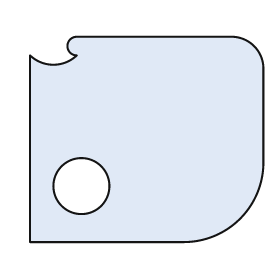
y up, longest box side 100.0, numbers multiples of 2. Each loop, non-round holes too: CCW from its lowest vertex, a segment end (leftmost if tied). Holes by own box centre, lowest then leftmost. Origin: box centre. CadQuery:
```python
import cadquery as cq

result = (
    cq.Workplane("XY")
    .moveTo(-50.0, -44.0)
    .lineTo(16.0, -44.0)
    .threePointArc((40.0, -34.0), (50.0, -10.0))
    .lineTo(50.0, 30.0)
    .threePointArc((46.0, 40.0), (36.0, 44.0))
    .lineTo(-30.0, 44.0)
    .threePointArc((-34.0, 40.0), (-30.0, 36.0))
    .threePointArc((-40.0, 32.0), (-50.0, 36.0))
    .close()
    .moveTo(-28.0, -20.0)
    .circle(12.0)
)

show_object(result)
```